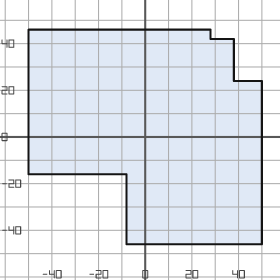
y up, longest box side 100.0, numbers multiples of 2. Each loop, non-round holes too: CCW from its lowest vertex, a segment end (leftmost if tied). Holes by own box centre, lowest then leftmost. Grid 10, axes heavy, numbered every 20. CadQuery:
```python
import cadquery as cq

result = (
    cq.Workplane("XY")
    .moveTo(-8.0, -46.0)
    .lineTo(50.0, -46.0)
    .lineTo(50.0, 24.0)
    .lineTo(38.0, 24.0)
    .lineTo(38.0, 42.0)
    .lineTo(28.0, 42.0)
    .lineTo(28.0, 46.0)
    .lineTo(-50.0, 46.0)
    .lineTo(-50.0, -16.0)
    .lineTo(-8.0, -16.0)
    .close()
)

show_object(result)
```